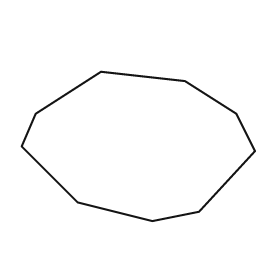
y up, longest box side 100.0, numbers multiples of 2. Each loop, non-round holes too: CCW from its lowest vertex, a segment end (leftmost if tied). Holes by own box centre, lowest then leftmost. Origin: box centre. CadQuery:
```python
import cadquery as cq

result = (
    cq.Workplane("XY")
    .moveTo(6.0, -32.0)
    .lineTo(26.0, -28.0)
    .lineTo(50.0, -2.0)
    .lineTo(42.0, 14.0)
    .lineTo(20.0, 28.0)
    .lineTo(-16.0, 32.0)
    .lineTo(-44.0, 14.0)
    .lineTo(-50.0, 0.0)
    .lineTo(-26.0, -24.0)
    .close()
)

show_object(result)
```